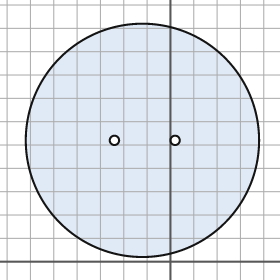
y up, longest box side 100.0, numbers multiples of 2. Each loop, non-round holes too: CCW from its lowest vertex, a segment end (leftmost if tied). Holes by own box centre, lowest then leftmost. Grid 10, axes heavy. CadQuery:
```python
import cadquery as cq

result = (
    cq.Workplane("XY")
    .moveTo(-12.0, 52.0)
    .circle(50.0)
    .moveTo(-24.0, 52.0)
    .circle(2.0)
    .moveTo(2.0, 52.0)
    .circle(2.0)
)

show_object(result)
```